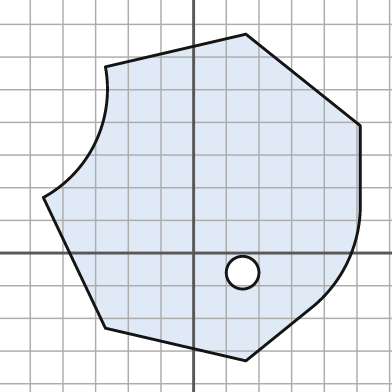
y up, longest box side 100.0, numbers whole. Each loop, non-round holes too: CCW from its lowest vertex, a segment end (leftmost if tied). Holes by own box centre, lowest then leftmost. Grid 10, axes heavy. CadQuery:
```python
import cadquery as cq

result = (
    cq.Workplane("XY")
    .moveTo(16.0, -33.0)
    .lineTo(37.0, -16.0)
    .threePointArc((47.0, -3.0), (51.0, 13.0))
    .lineTo(51.0, 39.0)
    .lineTo(16.0, 67.0)
    .lineTo(-27.0, 57.0)
    .threePointArc((-30.0, 34.0), (-46.0, 17.0))
    .lineTo(-27.0, -23.0)
    .close()
    .moveTo(15.0, -6.0)
    .circle(5.0)
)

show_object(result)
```